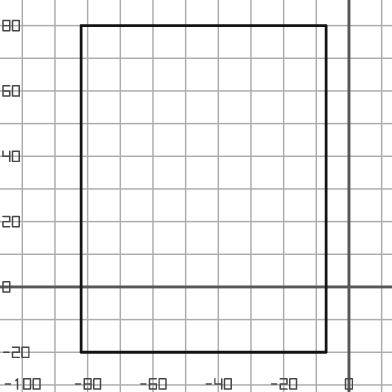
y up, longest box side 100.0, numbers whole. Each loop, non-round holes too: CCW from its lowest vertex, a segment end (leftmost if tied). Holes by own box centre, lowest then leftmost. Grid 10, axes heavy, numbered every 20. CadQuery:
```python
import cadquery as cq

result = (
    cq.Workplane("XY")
    .moveTo(-82.0, -20.0)
    .lineTo(-7.0, -20.0)
    .lineTo(-7.0, 80.0)
    .lineTo(-82.0, 80.0)
    .close()
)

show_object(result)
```